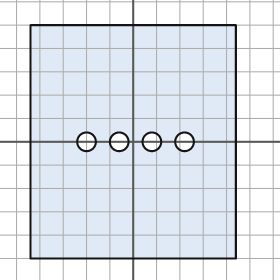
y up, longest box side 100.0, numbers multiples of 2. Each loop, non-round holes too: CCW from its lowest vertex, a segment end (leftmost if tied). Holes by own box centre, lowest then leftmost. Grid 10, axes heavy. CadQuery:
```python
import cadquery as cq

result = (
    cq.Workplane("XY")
    .moveTo(-44.0, -50.0)
    .lineTo(44.0, -50.0)
    .lineTo(44.0, 50.0)
    .lineTo(-44.0, 50.0)
    .close()
    .moveTo(-20.0, 0.0)
    .circle(4.0)
    .moveTo(-6.0, 0.0)
    .circle(4.0)
    .moveTo(8.0, 0.0)
    .circle(4.0)
    .moveTo(22.0, 0.0)
    .circle(4.0)
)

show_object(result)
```